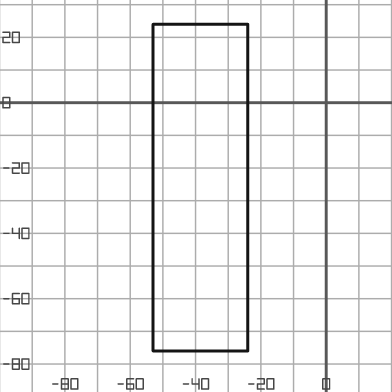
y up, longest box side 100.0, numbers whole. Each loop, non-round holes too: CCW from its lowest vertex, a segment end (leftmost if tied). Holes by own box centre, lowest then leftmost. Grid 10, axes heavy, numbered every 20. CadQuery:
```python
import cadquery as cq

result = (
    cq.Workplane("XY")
    .moveTo(-53.0, -76.0)
    .lineTo(-24.0, -76.0)
    .lineTo(-24.0, 24.0)
    .lineTo(-53.0, 24.0)
    .close()
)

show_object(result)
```